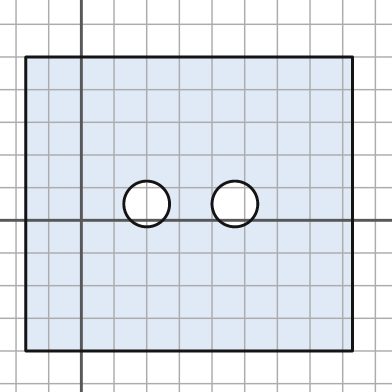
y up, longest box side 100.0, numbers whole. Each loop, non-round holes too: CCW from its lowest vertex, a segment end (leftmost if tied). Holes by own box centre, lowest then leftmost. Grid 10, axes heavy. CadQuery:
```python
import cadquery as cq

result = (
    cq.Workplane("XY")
    .moveTo(-17.0, -40.0)
    .lineTo(83.0, -40.0)
    .lineTo(83.0, 50.0)
    .lineTo(-17.0, 50.0)
    .close()
    .moveTo(20.0, 5.0)
    .circle(7.0)
    .moveTo(47.0, 5.0)
    .circle(7.0)
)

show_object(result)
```